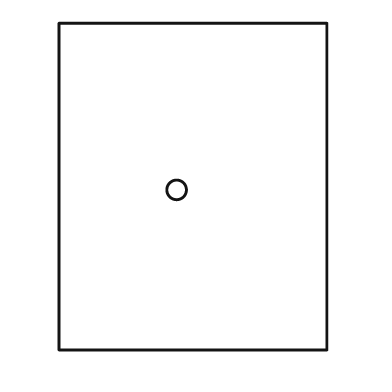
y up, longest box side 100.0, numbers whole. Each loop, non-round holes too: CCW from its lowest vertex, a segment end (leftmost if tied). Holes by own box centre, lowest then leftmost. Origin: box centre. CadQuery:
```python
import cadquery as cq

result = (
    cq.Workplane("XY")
    .moveTo(-41.0, -50.0)
    .lineTo(41.0, -50.0)
    .lineTo(41.0, 50.0)
    .lineTo(-41.0, 50.0)
    .close()
    .moveTo(-5.0, -1.0)
    .circle(3.0)
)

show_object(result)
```